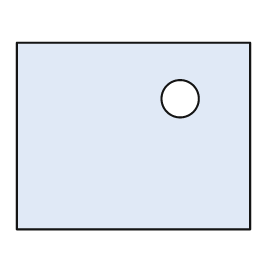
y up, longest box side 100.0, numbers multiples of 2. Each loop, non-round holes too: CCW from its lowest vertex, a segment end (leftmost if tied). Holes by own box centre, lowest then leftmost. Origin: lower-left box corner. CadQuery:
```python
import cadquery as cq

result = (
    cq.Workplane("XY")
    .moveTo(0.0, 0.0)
    .lineTo(100.0, 0.0)
    .lineTo(100.0, 80.0)
    .lineTo(0.0, 80.0)
    .close()
    .moveTo(70.0, 56.0)
    .circle(8.0)
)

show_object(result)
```